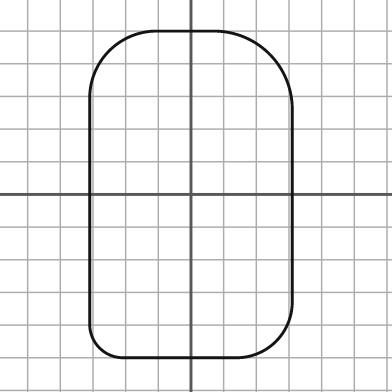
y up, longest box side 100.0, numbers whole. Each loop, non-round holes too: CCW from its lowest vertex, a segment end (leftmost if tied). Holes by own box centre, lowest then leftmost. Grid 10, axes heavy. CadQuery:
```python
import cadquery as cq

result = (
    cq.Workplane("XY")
    .moveTo(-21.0, -50.0)
    .lineTo(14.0, -50.0)
    .threePointArc((26.0, -45.0), (31.0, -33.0))
    .lineTo(31.0, 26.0)
    .threePointArc((24.0, 43.0), (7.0, 50.0))
    .lineTo(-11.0, 50.0)
    .threePointArc((-25.0, 44.0), (-31.0, 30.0))
    .lineTo(-31.0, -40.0)
    .threePointArc((-28.0, -47.0), (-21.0, -50.0))
    .close()
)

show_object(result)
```